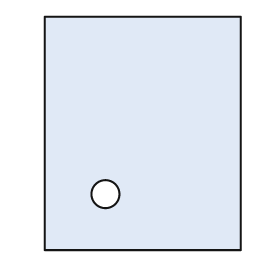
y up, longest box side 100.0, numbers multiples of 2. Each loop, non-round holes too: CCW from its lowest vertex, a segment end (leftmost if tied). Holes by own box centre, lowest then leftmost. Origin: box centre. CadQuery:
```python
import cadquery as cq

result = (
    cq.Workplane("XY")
    .moveTo(-42.0, -50.0)
    .lineTo(42.0, -50.0)
    .lineTo(42.0, 50.0)
    .lineTo(-42.0, 50.0)
    .close()
    .moveTo(-16.0, -26.0)
    .circle(6.0)
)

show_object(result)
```